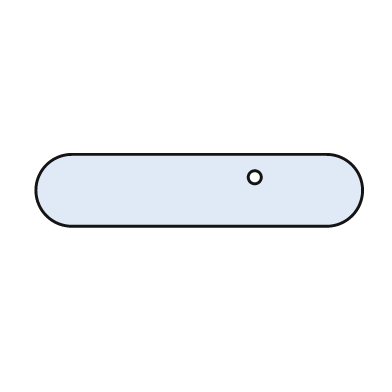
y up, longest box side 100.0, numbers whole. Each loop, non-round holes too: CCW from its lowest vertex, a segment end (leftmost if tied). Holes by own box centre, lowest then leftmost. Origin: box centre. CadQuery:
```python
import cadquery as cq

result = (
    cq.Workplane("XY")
    .moveTo(-39.0, -11.0)
    .lineTo(39.0, -11.0)
    .threePointArc((50.0, 0.0), (39.0, 11.0))
    .lineTo(-39.0, 11.0)
    .threePointArc((-50.0, 0.0), (-39.0, -11.0))
    .close()
    .moveTo(17.0, 4.0)
    .circle(2.0)
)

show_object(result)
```